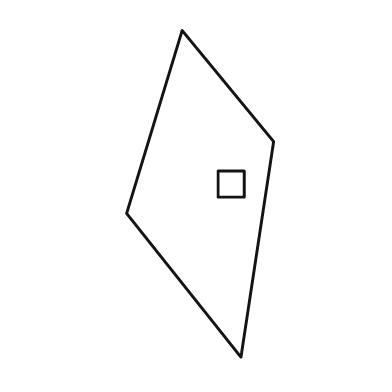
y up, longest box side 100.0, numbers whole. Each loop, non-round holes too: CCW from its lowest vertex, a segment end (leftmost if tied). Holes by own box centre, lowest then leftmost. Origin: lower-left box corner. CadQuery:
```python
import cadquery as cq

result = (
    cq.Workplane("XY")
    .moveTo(35.0, 0.0)
    .lineTo(45.0, 66.0)
    .lineTo(17.0, 100.0)
    .lineTo(0.0, 44.0)
    .close()
    .moveTo(28.0, 49.0)
    .lineTo(36.0, 49.0)
    .lineTo(36.0, 57.0)
    .lineTo(28.0, 57.0)
    .close()
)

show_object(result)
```